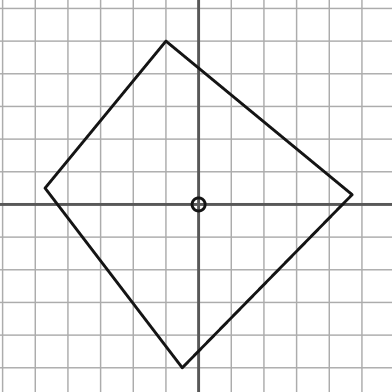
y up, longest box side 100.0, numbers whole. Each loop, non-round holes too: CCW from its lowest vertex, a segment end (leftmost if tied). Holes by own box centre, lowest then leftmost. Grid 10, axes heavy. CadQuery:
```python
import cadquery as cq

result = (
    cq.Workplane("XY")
    .moveTo(-5.0, -50.0)
    .lineTo(47.0, 3.0)
    .lineTo(-10.0, 50.0)
    .lineTo(-47.0, 5.0)
    .close()
    .moveTo(0.0, 0.0)
    .circle(2.0)
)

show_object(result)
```